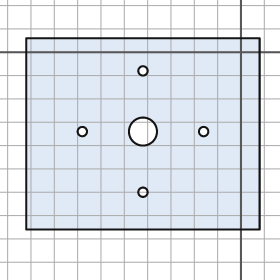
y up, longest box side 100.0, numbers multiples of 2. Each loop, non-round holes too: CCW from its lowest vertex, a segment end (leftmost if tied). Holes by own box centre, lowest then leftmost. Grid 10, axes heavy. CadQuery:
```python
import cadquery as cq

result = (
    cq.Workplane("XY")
    .moveTo(-92.0, -76.0)
    .lineTo(8.0, -76.0)
    .lineTo(8.0, 6.0)
    .lineTo(-92.0, 6.0)
    .close()
    .moveTo(-42.0, -60.0)
    .circle(2.0)
    .moveTo(-68.0, -34.0)
    .circle(2.0)
    .moveTo(-42.0, -34.0)
    .circle(6.0)
    .moveTo(-16.0, -34.0)
    .circle(2.0)
    .moveTo(-42.0, -8.0)
    .circle(2.0)
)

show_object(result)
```